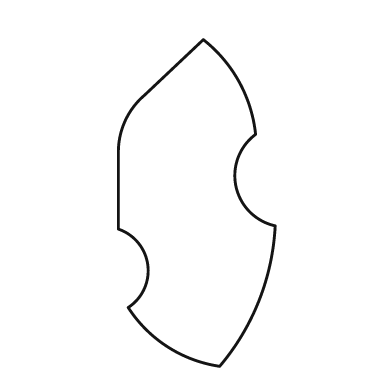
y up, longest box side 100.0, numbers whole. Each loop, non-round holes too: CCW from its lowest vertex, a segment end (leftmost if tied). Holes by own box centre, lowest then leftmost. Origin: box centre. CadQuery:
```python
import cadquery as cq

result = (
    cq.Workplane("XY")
    .moveTo(7.0, -50.0)
    .threePointArc((19.0, -30.0), (24.0, -7.0))
    .threePointArc((12.0, 5.0), (18.0, 21.0))
    .threePointArc((13.0, 37.0), (2.0, 50.0))
    .lineTo(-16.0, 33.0)
    .threePointArc((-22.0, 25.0), (-24.0, 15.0))
    .lineTo(-24.0, -8.0)
    .threePointArc((-15.0, -19.0), (-21.0, -32.0))
    .threePointArc((-9.0, -44.0), (7.0, -50.0))
    .close()
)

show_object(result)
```